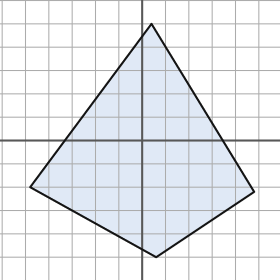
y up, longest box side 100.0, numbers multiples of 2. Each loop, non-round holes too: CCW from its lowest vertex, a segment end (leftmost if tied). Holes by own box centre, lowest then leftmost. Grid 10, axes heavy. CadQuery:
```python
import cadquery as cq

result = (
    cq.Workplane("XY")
    .moveTo(6.0, -50.0)
    .lineTo(48.0, -22.0)
    .lineTo(4.0, 50.0)
    .lineTo(-48.0, -20.0)
    .close()
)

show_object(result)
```